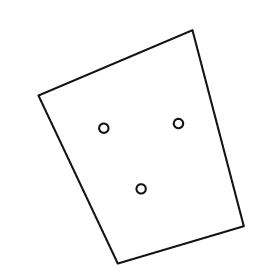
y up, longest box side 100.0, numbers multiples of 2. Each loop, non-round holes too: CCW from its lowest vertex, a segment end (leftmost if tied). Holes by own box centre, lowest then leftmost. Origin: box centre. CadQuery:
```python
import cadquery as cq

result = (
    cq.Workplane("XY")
    .moveTo(-10.0, -50.0)
    .lineTo(44.0, -34.0)
    .lineTo(22.0, 50.0)
    .lineTo(-44.0, 22.0)
    .close()
    .moveTo(0.0, -18.0)
    .circle(2.0)
    .moveTo(-16.0, 8.0)
    .circle(2.0)
    .moveTo(16.0, 10.0)
    .circle(2.0)
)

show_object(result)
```